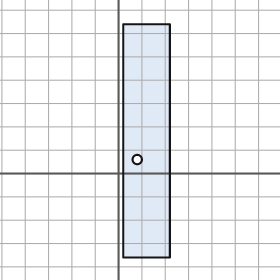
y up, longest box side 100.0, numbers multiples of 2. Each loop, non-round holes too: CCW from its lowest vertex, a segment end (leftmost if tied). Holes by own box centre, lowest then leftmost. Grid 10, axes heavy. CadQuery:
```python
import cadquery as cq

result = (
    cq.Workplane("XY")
    .moveTo(2.0, -36.0)
    .lineTo(22.0, -36.0)
    .lineTo(22.0, 64.0)
    .lineTo(2.0, 64.0)
    .close()
    .moveTo(8.0, 6.0)
    .circle(2.0)
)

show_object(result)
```